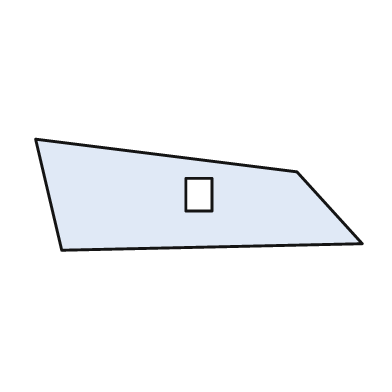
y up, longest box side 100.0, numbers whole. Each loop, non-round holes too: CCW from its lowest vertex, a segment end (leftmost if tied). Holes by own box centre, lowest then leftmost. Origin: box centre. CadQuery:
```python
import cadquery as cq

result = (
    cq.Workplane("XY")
    .moveTo(-42.0, -17.0)
    .lineTo(50.0, -15.0)
    .lineTo(30.0, 7.0)
    .lineTo(-50.0, 17.0)
    .close()
    .moveTo(-4.0, -5.0)
    .lineTo(4.0, -5.0)
    .lineTo(4.0, 5.0)
    .lineTo(-4.0, 5.0)
    .close()
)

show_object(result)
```